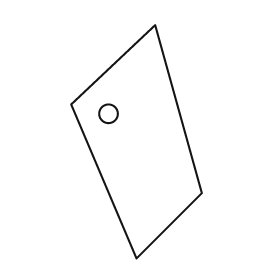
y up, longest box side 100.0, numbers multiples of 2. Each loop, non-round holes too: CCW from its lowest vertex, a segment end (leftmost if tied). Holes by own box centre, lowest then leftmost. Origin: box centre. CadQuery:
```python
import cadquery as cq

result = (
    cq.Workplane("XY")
    .moveTo(0.0, -50.0)
    .lineTo(28.0, -22.0)
    .lineTo(8.0, 50.0)
    .lineTo(-28.0, 16.0)
    .close()
    .moveTo(-12.0, 12.0)
    .circle(4.0)
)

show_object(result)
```